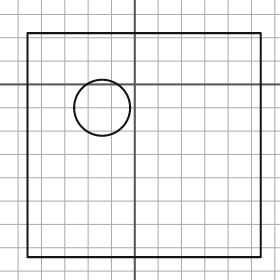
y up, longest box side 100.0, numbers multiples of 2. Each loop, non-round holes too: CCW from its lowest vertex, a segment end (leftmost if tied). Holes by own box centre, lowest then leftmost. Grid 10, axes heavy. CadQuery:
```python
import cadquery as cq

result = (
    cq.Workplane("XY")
    .moveTo(-46.0, -74.0)
    .lineTo(54.0, -74.0)
    .lineTo(54.0, 22.0)
    .lineTo(-46.0, 22.0)
    .close()
    .moveTo(-14.0, -10.0)
    .circle(12.0)
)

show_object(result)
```